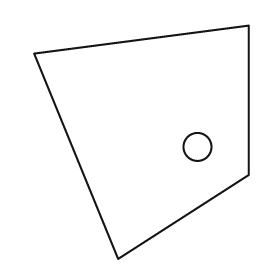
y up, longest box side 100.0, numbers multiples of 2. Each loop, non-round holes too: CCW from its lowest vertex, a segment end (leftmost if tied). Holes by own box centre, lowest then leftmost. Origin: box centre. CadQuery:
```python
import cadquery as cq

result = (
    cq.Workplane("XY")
    .moveTo(-10.0, -50.0)
    .lineTo(46.0, -14.0)
    .lineTo(46.0, 50.0)
    .lineTo(-46.0, 38.0)
    .close()
    .moveTo(24.0, -2.0)
    .circle(6.0)
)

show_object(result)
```